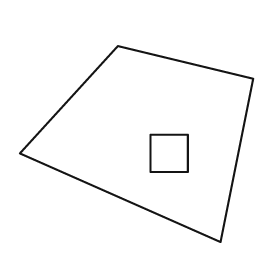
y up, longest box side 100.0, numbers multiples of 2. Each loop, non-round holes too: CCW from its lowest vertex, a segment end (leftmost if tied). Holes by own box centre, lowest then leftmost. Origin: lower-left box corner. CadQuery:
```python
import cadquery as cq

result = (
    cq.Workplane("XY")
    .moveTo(86.0, 0.0)
    .lineTo(100.0, 70.0)
    .lineTo(42.0, 84.0)
    .lineTo(0.0, 38.0)
    .close()
    .moveTo(56.0, 30.0)
    .lineTo(72.0, 30.0)
    .lineTo(72.0, 46.0)
    .lineTo(56.0, 46.0)
    .close()
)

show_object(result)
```